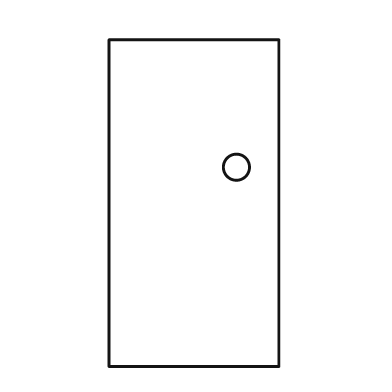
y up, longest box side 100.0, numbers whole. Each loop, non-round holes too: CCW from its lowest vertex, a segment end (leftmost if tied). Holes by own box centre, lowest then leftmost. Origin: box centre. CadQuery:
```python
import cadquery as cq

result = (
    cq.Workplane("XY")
    .moveTo(-26.0, -50.0)
    .lineTo(26.0, -50.0)
    .lineTo(26.0, 50.0)
    .lineTo(-26.0, 50.0)
    .close()
    .moveTo(13.0, 11.0)
    .circle(4.0)
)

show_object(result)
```